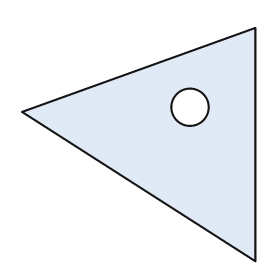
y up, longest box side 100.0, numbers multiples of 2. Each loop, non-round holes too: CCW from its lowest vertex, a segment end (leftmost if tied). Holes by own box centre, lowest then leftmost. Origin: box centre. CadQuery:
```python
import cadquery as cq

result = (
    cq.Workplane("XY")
    .moveTo(50.0, -50.0)
    .lineTo(50.0, 50.0)
    .lineTo(-50.0, 14.0)
    .close()
    .moveTo(22.0, 16.0)
    .circle(8.0)
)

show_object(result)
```